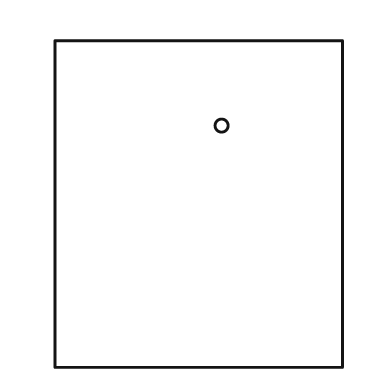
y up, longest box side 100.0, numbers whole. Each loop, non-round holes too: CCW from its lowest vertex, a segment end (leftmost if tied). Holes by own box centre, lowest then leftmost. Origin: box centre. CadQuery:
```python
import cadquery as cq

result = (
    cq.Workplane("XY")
    .moveTo(-44.0, -50.0)
    .lineTo(44.0, -50.0)
    .lineTo(44.0, 50.0)
    .lineTo(-44.0, 50.0)
    .close()
    .moveTo(7.0, 24.0)
    .circle(2.0)
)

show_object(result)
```